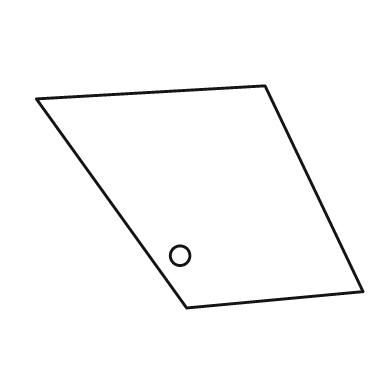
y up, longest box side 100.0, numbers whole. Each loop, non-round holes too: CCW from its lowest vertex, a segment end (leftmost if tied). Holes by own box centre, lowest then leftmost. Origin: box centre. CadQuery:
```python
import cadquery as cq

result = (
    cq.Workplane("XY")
    .moveTo(-4.0, -34.0)
    .lineTo(50.0, -29.0)
    .lineTo(20.0, 34.0)
    .lineTo(-50.0, 30.0)
    .close()
    .moveTo(-6.0, -18.0)
    .circle(3.0)
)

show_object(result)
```